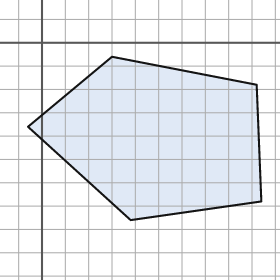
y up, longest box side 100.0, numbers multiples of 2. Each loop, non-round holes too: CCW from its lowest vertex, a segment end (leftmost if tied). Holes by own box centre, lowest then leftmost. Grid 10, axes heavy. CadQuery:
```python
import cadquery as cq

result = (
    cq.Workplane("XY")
    .moveTo(38.0, -76.0)
    .lineTo(94.0, -68.0)
    .lineTo(92.0, -18.0)
    .lineTo(30.0, -6.0)
    .lineTo(-6.0, -36.0)
    .close()
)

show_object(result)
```